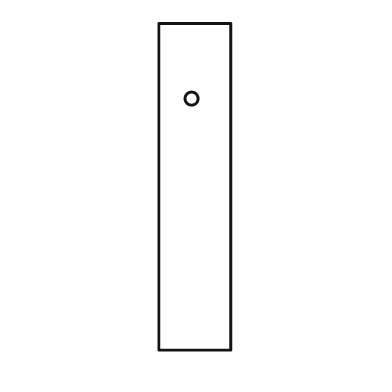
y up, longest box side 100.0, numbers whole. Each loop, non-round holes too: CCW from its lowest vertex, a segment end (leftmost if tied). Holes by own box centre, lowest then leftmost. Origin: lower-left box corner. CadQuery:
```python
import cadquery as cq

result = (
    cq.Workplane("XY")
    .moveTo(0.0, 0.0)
    .lineTo(22.0, 0.0)
    .lineTo(22.0, 100.0)
    .lineTo(0.0, 100.0)
    .close()
    .moveTo(10.0, 77.0)
    .circle(2.0)
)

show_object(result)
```